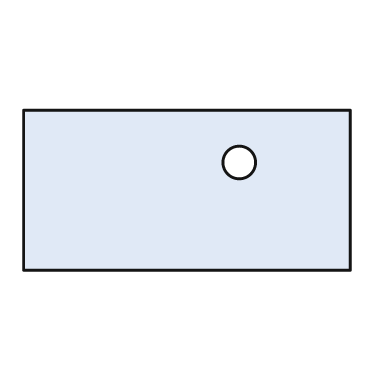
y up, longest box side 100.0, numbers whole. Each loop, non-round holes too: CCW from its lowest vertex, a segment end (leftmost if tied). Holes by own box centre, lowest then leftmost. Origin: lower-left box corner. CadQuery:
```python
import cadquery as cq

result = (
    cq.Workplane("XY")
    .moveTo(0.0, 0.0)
    .lineTo(100.0, 0.0)
    .lineTo(100.0, 49.0)
    .lineTo(0.0, 49.0)
    .close()
    .moveTo(66.0, 33.0)
    .circle(5.0)
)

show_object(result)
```